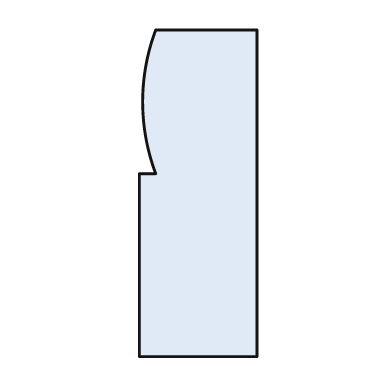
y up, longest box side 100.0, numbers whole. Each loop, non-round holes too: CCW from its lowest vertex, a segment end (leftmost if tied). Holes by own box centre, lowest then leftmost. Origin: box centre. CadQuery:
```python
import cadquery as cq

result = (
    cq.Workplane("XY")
    .moveTo(-18.0, -50.0)
    .lineTo(18.0, -50.0)
    .lineTo(18.0, 50.0)
    .lineTo(-13.0, 50.0)
    .threePointArc((-17.0, 28.0), (-13.0, 6.0))
    .lineTo(-18.0, 6.0)
    .close()
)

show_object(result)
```